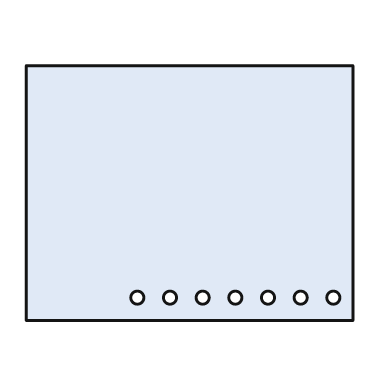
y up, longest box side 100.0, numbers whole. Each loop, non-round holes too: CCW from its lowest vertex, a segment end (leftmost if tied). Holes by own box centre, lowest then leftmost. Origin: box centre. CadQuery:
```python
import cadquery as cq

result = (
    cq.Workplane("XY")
    .moveTo(-50.0, -39.0)
    .lineTo(50.0, -39.0)
    .lineTo(50.0, 39.0)
    .lineTo(-50.0, 39.0)
    .close()
    .moveTo(-16.0, -32.0)
    .circle(2.0)
    .moveTo(-6.0, -32.0)
    .circle(2.0)
    .moveTo(4.0, -32.0)
    .circle(2.0)
    .moveTo(14.0, -32.0)
    .circle(2.0)
    .moveTo(24.0, -32.0)
    .circle(2.0)
    .moveTo(34.0, -32.0)
    .circle(2.0)
    .moveTo(44.0, -32.0)
    .circle(2.0)
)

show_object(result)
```